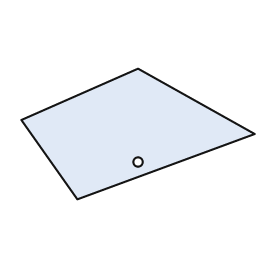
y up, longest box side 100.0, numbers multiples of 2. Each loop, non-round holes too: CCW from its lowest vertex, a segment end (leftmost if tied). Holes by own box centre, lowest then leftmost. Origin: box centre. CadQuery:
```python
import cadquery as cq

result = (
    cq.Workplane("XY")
    .moveTo(-26.0, -28.0)
    .lineTo(50.0, 0.0)
    .lineTo(0.0, 28.0)
    .lineTo(-50.0, 6.0)
    .close()
    .moveTo(0.0, -12.0)
    .circle(2.0)
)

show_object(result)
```